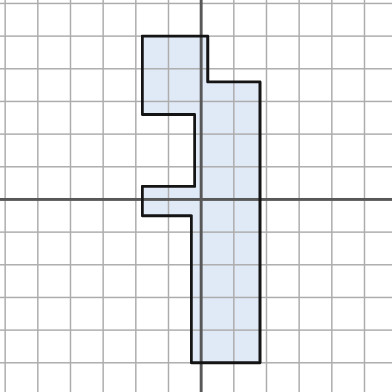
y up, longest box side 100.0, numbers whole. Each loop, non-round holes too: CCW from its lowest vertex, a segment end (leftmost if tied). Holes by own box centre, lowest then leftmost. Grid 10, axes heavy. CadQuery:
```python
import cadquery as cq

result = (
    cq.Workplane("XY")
    .moveTo(-3.0, -50.0)
    .lineTo(18.0, -50.0)
    .lineTo(18.0, 36.0)
    .lineTo(2.0, 36.0)
    .lineTo(2.0, 50.0)
    .lineTo(-18.0, 50.0)
    .lineTo(-18.0, 26.0)
    .lineTo(-2.0, 26.0)
    .lineTo(-2.0, 4.0)
    .lineTo(-18.0, 4.0)
    .lineTo(-18.0, -5.0)
    .lineTo(-3.0, -5.0)
    .close()
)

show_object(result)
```